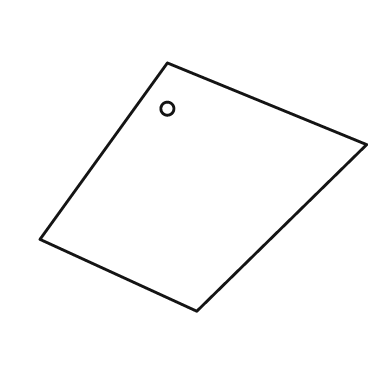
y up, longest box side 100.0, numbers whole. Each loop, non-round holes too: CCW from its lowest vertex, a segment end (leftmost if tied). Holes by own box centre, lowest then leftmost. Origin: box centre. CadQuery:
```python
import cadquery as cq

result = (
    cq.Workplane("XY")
    .moveTo(-2.0, -38.0)
    .lineTo(50.0, 13.0)
    .lineTo(-11.0, 38.0)
    .lineTo(-50.0, -16.0)
    .close()
    .moveTo(-11.0, 24.0)
    .circle(2.0)
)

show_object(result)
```